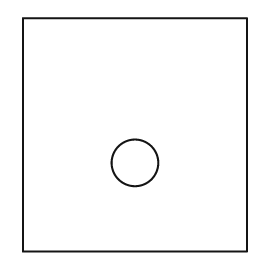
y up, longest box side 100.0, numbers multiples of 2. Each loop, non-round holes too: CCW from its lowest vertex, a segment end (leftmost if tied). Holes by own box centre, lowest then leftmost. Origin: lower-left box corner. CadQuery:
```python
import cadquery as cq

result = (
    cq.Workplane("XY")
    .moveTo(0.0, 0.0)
    .lineTo(96.0, 0.0)
    .lineTo(96.0, 100.0)
    .lineTo(0.0, 100.0)
    .close()
    .moveTo(48.0, 38.0)
    .circle(10.0)
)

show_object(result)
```